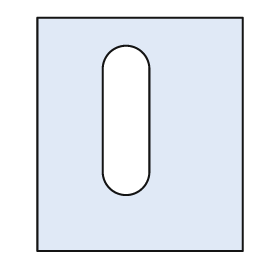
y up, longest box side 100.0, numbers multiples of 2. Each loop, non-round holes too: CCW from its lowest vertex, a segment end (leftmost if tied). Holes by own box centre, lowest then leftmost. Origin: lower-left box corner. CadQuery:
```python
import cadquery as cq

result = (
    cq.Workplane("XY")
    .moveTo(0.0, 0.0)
    .lineTo(88.0, 0.0)
    .lineTo(88.0, 100.0)
    .lineTo(0.0, 100.0)
    .close()
    .moveTo(28.0, 34.0)
    .threePointArc((38.0, 24.0), (48.0, 34.0))
    .lineTo(48.0, 78.0)
    .threePointArc((38.0, 88.0), (28.0, 78.0))
    .close()
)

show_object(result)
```